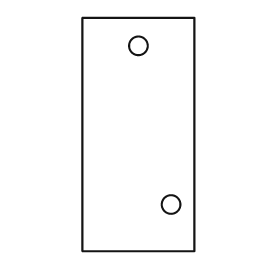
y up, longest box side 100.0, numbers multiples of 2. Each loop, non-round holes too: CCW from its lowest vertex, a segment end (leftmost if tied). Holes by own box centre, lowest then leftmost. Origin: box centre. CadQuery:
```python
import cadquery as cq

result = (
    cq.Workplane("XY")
    .moveTo(-24.0, -50.0)
    .lineTo(24.0, -50.0)
    .lineTo(24.0, 50.0)
    .lineTo(-24.0, 50.0)
    .close()
    .moveTo(14.0, -30.0)
    .circle(4.0)
    .moveTo(0.0, 38.0)
    .circle(4.0)
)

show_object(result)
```